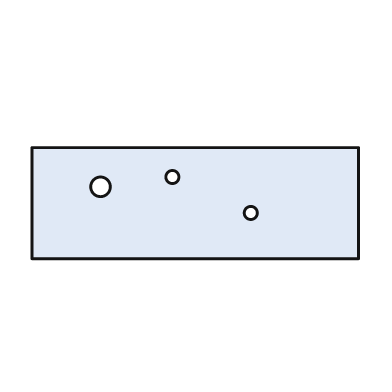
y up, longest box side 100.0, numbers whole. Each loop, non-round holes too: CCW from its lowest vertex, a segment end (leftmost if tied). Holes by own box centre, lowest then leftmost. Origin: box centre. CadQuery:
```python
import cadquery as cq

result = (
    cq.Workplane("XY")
    .moveTo(-50.0, -17.0)
    .lineTo(50.0, -17.0)
    .lineTo(50.0, 17.0)
    .lineTo(-50.0, 17.0)
    .close()
    .moveTo(17.0, -3.0)
    .circle(2.0)
    .moveTo(-29.0, 5.0)
    .circle(3.0)
    .moveTo(-7.0, 8.0)
    .circle(2.0)
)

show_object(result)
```